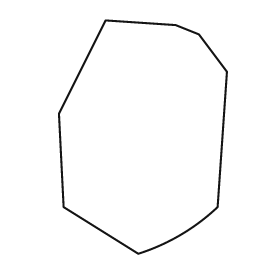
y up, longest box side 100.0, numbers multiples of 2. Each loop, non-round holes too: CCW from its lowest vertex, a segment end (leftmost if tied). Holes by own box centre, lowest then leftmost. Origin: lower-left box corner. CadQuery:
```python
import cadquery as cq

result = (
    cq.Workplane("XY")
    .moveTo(34.0, 0.0)
    .threePointArc((52.0, 8.0), (68.0, 20.0))
    .lineTo(72.0, 78.0)
    .lineTo(60.0, 94.0)
    .lineTo(50.0, 98.0)
    .lineTo(20.0, 100.0)
    .lineTo(0.0, 60.0)
    .lineTo(2.0, 20.0)
    .close()
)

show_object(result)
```